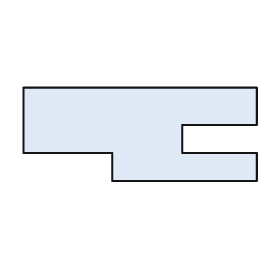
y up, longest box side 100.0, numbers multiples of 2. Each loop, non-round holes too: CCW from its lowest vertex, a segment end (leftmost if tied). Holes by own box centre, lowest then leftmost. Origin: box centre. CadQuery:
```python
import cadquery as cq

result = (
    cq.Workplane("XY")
    .moveTo(-12.0, -20.0)
    .lineTo(50.0, -20.0)
    .lineTo(50.0, -8.0)
    .lineTo(18.0, -8.0)
    .lineTo(18.0, 4.0)
    .lineTo(50.0, 4.0)
    .lineTo(50.0, 20.0)
    .lineTo(-50.0, 20.0)
    .lineTo(-50.0, -8.0)
    .lineTo(-12.0, -8.0)
    .close()
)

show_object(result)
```